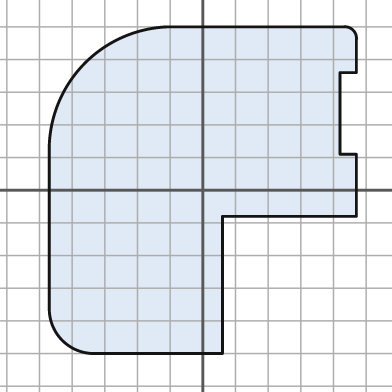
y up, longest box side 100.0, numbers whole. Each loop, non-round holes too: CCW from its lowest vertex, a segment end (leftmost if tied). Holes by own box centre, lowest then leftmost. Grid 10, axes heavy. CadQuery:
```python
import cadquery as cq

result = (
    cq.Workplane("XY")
    .moveTo(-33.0, -50.0)
    .lineTo(6.0, -50.0)
    .lineTo(6.0, -8.0)
    .lineTo(47.0, -8.0)
    .lineTo(47.0, 11.0)
    .lineTo(42.0, 11.0)
    .lineTo(42.0, 36.0)
    .lineTo(47.0, 36.0)
    .lineTo(47.0, 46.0)
    .threePointArc((46.0, 49.0), (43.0, 50.0))
    .lineTo(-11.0, 50.0)
    .threePointArc((-36.0, 39.0), (-47.0, 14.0))
    .lineTo(-47.0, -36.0)
    .threePointArc((-43.0, -46.0), (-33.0, -50.0))
    .close()
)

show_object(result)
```